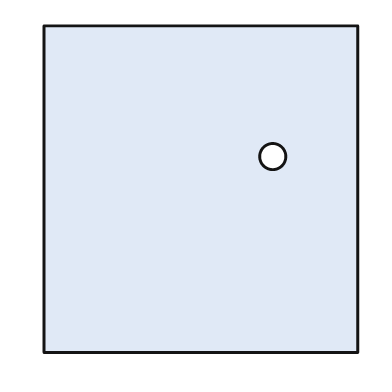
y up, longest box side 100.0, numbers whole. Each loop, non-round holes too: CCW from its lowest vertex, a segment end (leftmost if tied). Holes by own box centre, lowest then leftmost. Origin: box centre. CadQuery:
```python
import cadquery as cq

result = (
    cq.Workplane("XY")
    .moveTo(-48.0, -50.0)
    .lineTo(48.0, -50.0)
    .lineTo(48.0, 50.0)
    .lineTo(-48.0, 50.0)
    .close()
    .moveTo(22.0, 10.0)
    .circle(4.0)
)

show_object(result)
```